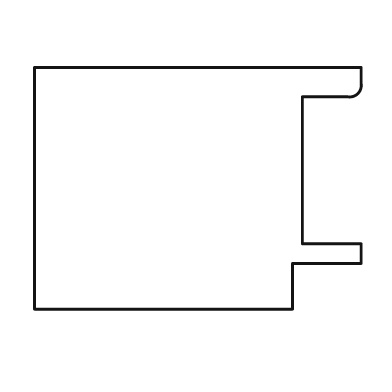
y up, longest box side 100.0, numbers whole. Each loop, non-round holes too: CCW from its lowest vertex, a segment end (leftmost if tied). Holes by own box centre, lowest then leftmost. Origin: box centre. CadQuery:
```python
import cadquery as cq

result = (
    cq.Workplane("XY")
    .moveTo(-50.0, -37.0)
    .lineTo(29.0, -37.0)
    .lineTo(29.0, -23.0)
    .lineTo(50.0, -23.0)
    .lineTo(50.0, -17.0)
    .lineTo(32.0, -17.0)
    .lineTo(32.0, 28.0)
    .lineTo(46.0, 28.0)
    .threePointArc((49.0, 29.0), (50.0, 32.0))
    .lineTo(50.0, 37.0)
    .lineTo(-50.0, 37.0)
    .close()
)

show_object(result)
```